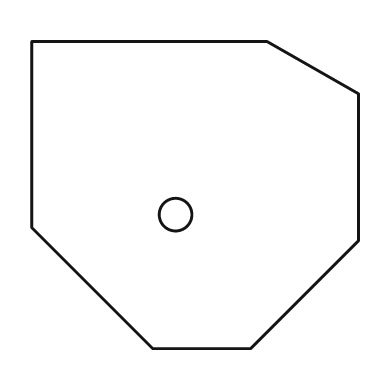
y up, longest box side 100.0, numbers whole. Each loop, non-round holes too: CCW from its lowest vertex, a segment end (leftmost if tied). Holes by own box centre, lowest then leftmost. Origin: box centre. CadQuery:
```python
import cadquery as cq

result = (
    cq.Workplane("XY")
    .moveTo(-13.0, -47.0)
    .lineTo(17.0, -47.0)
    .lineTo(50.0, -14.0)
    .lineTo(50.0, 31.0)
    .lineTo(22.0, 47.0)
    .lineTo(-50.0, 47.0)
    .lineTo(-50.0, -10.0)
    .close()
    .moveTo(-6.0, -6.0)
    .circle(5.0)
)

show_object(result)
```